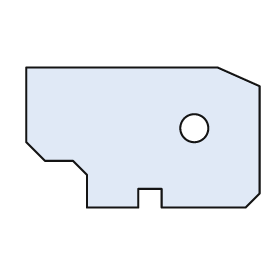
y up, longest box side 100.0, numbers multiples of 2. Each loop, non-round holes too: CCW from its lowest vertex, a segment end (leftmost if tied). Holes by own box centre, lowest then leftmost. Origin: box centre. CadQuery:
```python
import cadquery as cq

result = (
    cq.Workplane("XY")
    .moveTo(-24.0, -30.0)
    .lineTo(-2.0, -30.0)
    .lineTo(-2.0, -22.0)
    .lineTo(8.0, -22.0)
    .lineTo(8.0, -30.0)
    .lineTo(44.0, -30.0)
    .lineTo(50.0, -24.0)
    .lineTo(50.0, 22.0)
    .lineTo(32.0, 30.0)
    .lineTo(-50.0, 30.0)
    .lineTo(-50.0, -2.0)
    .lineTo(-42.0, -10.0)
    .lineTo(-30.0, -10.0)
    .lineTo(-24.0, -16.0)
    .close()
    .moveTo(22.0, 4.0)
    .circle(6.0)
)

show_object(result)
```